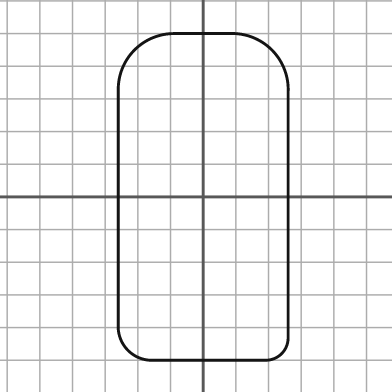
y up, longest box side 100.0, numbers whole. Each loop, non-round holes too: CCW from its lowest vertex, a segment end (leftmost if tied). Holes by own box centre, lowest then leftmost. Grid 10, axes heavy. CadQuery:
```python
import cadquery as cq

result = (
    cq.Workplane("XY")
    .moveTo(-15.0, -50.0)
    .lineTo(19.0, -50.0)
    .threePointArc((24.0, -48.0), (26.0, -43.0))
    .lineTo(26.0, 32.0)
    .threePointArc((21.0, 45.0), (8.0, 50.0))
    .lineTo(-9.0, 50.0)
    .threePointArc((-21.0, 45.0), (-26.0, 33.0))
    .lineTo(-26.0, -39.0)
    .threePointArc((-23.0, -47.0), (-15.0, -50.0))
    .close()
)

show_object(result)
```